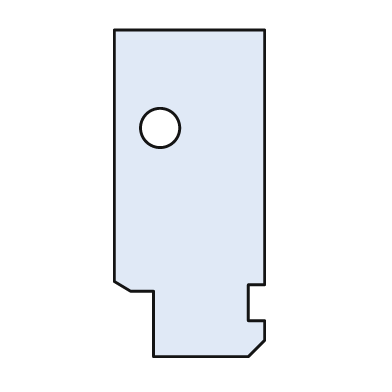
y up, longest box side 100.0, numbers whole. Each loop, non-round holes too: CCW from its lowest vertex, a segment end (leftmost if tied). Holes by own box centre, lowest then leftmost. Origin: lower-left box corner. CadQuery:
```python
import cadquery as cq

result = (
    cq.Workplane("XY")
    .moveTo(12.0, 0.0)
    .lineTo(41.0, 0.0)
    .lineTo(46.0, 5.0)
    .lineTo(46.0, 11.0)
    .lineTo(41.0, 11.0)
    .lineTo(41.0, 22.0)
    .lineTo(46.0, 22.0)
    .lineTo(46.0, 100.0)
    .lineTo(0.0, 100.0)
    .lineTo(0.0, 23.0)
    .lineTo(5.0, 20.0)
    .lineTo(12.0, 20.0)
    .close()
    .moveTo(14.0, 70.0)
    .circle(6.0)
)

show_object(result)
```